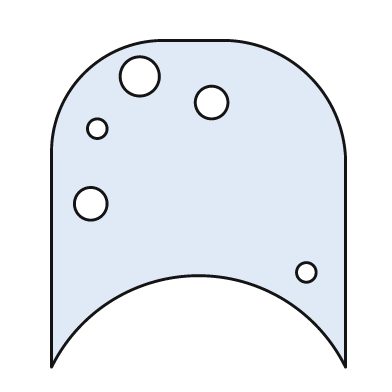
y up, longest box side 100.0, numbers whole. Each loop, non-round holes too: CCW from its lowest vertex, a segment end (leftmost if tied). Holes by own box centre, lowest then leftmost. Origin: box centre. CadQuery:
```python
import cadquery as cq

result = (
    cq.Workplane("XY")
    .moveTo(-45.0, -50.0)
    .threePointArc((0.0, -22.0), (45.0, -50.0))
    .lineTo(45.0, 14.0)
    .threePointArc((34.0, 39.0), (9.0, 50.0))
    .lineTo(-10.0, 50.0)
    .threePointArc((-35.0, 40.0), (-45.0, 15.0))
    .close()
    .moveTo(33.0, -21.0)
    .circle(3.0)
    .moveTo(-33.0, 0.0)
    .circle(5.0)
    .moveTo(-31.0, 23.0)
    .circle(3.0)
    .moveTo(4.0, 31.0)
    .circle(5.0)
    .moveTo(-18.0, 39.0)
    .circle(6.0)
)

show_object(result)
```